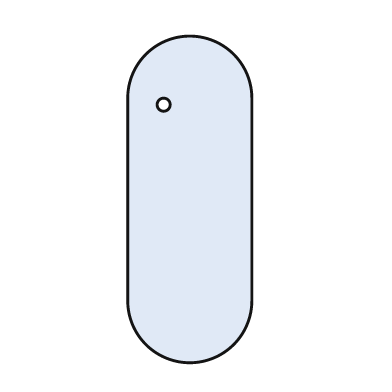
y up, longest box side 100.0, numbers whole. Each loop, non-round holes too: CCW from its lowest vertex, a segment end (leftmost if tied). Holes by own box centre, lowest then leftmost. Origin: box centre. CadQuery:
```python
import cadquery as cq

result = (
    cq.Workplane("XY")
    .moveTo(-19.0, -31.0)
    .threePointArc((0.0, -50.0), (19.0, -31.0))
    .lineTo(19.0, 31.0)
    .threePointArc((0.0, 50.0), (-19.0, 31.0))
    .close()
    .moveTo(-8.0, 29.0)
    .circle(2.0)
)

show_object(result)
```